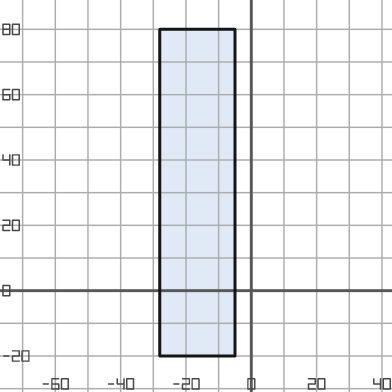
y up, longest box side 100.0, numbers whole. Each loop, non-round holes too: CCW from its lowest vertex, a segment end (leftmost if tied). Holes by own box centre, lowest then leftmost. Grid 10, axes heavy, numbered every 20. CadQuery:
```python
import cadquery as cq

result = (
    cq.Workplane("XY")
    .moveTo(-28.0, -20.0)
    .lineTo(-5.0, -20.0)
    .lineTo(-5.0, 80.0)
    .lineTo(-28.0, 80.0)
    .close()
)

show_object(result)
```